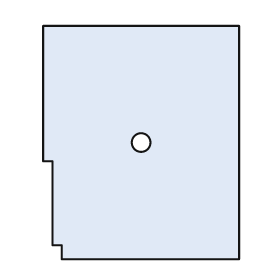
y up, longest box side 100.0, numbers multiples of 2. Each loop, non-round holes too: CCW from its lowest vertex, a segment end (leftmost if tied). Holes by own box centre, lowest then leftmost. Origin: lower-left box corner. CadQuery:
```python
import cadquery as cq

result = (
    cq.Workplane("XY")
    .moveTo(8.0, 0.0)
    .lineTo(84.0, 0.0)
    .lineTo(84.0, 100.0)
    .lineTo(0.0, 100.0)
    .lineTo(0.0, 42.0)
    .lineTo(4.0, 42.0)
    .lineTo(4.0, 6.0)
    .lineTo(8.0, 6.0)
    .close()
    .moveTo(42.0, 50.0)
    .circle(4.0)
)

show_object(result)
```